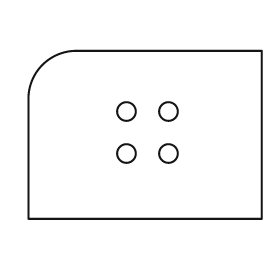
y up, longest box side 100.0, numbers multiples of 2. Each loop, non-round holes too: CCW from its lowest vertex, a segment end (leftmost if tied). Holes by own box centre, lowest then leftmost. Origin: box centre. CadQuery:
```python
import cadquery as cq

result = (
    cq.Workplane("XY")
    .moveTo(-50.0, -36.0)
    .lineTo(50.0, -36.0)
    .lineTo(50.0, 36.0)
    .lineTo(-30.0, 36.0)
    .threePointArc((-44.0, 30.0), (-50.0, 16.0))
    .close()
    .moveTo(-8.0, -8.0)
    .circle(4.0)
    .moveTo(10.0, -8.0)
    .circle(4.0)
    .moveTo(-8.0, 10.0)
    .circle(4.0)
    .moveTo(10.0, 10.0)
    .circle(4.0)
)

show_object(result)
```